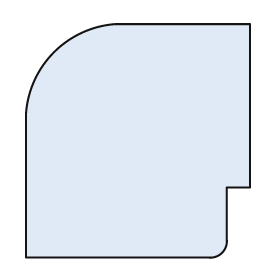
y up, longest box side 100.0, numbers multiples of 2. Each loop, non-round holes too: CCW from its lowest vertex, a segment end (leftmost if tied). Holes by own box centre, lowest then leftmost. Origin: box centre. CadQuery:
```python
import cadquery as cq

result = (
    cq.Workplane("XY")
    .moveTo(-48.0, -50.0)
    .lineTo(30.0, -50.0)
    .threePointArc((36.0, -48.0), (38.0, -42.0))
    .lineTo(38.0, -20.0)
    .lineTo(48.0, -20.0)
    .lineTo(48.0, 50.0)
    .lineTo(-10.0, 50.0)
    .threePointArc((-36.0, 38.0), (-48.0, 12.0))
    .close()
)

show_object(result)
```